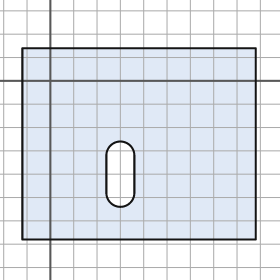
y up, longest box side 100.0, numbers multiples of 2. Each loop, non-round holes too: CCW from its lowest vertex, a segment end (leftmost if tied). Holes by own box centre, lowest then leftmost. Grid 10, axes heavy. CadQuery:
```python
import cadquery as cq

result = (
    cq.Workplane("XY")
    .moveTo(-12.0, -68.0)
    .lineTo(88.0, -68.0)
    .lineTo(88.0, 14.0)
    .lineTo(-12.0, 14.0)
    .close()
    .moveTo(24.0, -48.0)
    .threePointArc((30.0, -54.0), (36.0, -48.0))
    .lineTo(36.0, -32.0)
    .threePointArc((30.0, -26.0), (24.0, -32.0))
    .close()
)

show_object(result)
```